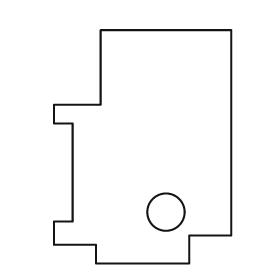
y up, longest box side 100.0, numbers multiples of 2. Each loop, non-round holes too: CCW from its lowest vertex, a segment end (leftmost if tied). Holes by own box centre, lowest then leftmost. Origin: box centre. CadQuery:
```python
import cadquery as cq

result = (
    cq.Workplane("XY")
    .moveTo(-20.0, -50.0)
    .lineTo(20.0, -50.0)
    .lineTo(20.0, -38.0)
    .lineTo(38.0, -38.0)
    .lineTo(38.0, 50.0)
    .lineTo(-18.0, 50.0)
    .lineTo(-18.0, 18.0)
    .lineTo(-38.0, 18.0)
    .lineTo(-38.0, 10.0)
    .lineTo(-30.0, 10.0)
    .lineTo(-30.0, -32.0)
    .lineTo(-38.0, -32.0)
    .lineTo(-38.0, -42.0)
    .lineTo(-20.0, -42.0)
    .close()
    .moveTo(10.0, -28.0)
    .circle(8.0)
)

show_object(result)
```